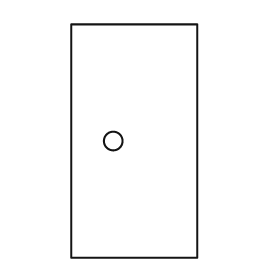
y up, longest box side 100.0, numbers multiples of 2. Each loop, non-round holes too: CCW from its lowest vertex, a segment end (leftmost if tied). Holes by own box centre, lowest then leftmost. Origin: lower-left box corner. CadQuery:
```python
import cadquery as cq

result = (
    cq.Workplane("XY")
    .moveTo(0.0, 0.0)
    .lineTo(54.0, 0.0)
    .lineTo(54.0, 100.0)
    .lineTo(0.0, 100.0)
    .close()
    .moveTo(18.0, 50.0)
    .circle(4.0)
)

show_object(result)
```